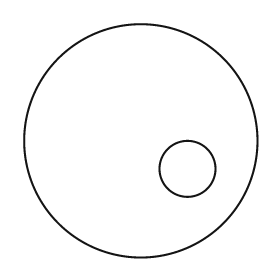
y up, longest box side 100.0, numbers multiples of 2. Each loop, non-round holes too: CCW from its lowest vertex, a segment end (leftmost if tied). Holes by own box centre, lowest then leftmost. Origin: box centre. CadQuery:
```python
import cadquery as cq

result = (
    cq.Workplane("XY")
    .moveTo(0.0, 0.0)
    .circle(50.0)
    .moveTo(20.0, -12.0)
    .circle(12.0)
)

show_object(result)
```